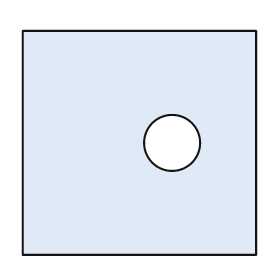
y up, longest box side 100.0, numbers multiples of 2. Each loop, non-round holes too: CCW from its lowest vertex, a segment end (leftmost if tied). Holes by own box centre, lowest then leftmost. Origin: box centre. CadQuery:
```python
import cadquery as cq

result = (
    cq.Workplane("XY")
    .moveTo(-50.0, -48.0)
    .lineTo(50.0, -48.0)
    .lineTo(50.0, 48.0)
    .lineTo(-50.0, 48.0)
    .close()
    .moveTo(14.0, 0.0)
    .circle(12.0)
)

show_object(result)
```